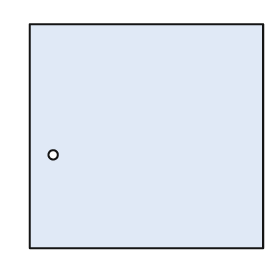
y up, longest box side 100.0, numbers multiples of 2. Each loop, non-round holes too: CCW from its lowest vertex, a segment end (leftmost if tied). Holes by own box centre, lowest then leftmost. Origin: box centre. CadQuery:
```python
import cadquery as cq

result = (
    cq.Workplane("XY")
    .moveTo(-50.0, -48.0)
    .lineTo(50.0, -48.0)
    .lineTo(50.0, 48.0)
    .lineTo(-50.0, 48.0)
    .close()
    .moveTo(-40.0, -8.0)
    .circle(2.0)
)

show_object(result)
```